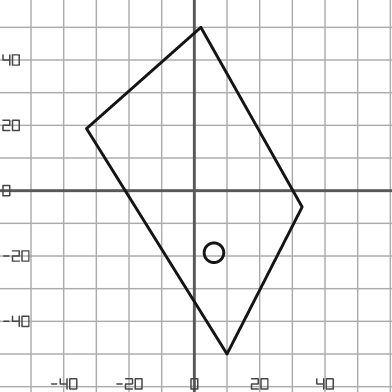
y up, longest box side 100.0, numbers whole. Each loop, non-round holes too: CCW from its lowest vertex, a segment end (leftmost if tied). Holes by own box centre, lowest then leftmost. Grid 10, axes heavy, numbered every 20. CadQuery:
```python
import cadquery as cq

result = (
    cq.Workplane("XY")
    .moveTo(10.0, -50.0)
    .lineTo(33.0, -5.0)
    .lineTo(2.0, 50.0)
    .lineTo(-33.0, 19.0)
    .close()
    .moveTo(6.0, -19.0)
    .circle(3.0)
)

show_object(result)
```